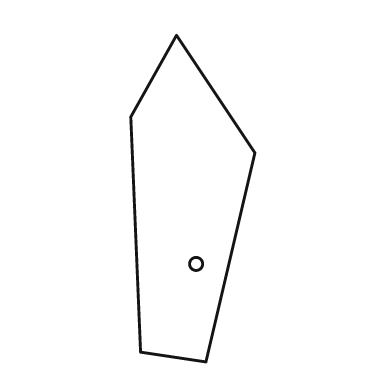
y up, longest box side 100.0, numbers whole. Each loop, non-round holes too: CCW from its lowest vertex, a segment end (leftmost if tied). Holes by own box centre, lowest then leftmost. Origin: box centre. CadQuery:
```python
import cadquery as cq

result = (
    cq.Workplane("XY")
    .moveTo(4.0, -50.0)
    .lineTo(19.0, 14.0)
    .lineTo(-5.0, 50.0)
    .lineTo(-19.0, 25.0)
    .lineTo(-16.0, -47.0)
    .close()
    .moveTo(1.0, -20.0)
    .circle(2.0)
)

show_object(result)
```